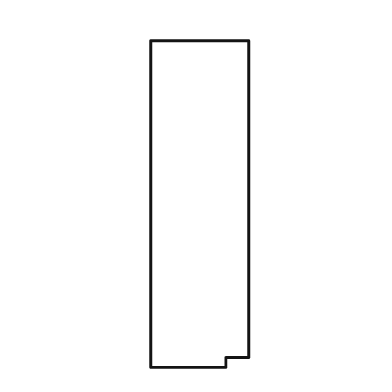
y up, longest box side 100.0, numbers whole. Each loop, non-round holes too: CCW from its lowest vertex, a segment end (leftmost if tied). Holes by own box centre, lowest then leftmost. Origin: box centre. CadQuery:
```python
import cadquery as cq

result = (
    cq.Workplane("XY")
    .moveTo(-15.0, -50.0)
    .lineTo(8.0, -50.0)
    .lineTo(8.0, -47.0)
    .lineTo(15.0, -47.0)
    .lineTo(15.0, 50.0)
    .lineTo(-15.0, 50.0)
    .close()
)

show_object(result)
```